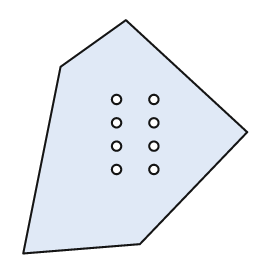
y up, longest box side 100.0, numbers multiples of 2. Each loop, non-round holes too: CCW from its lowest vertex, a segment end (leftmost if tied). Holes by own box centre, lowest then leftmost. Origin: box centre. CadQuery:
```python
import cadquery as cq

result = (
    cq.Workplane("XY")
    .moveTo(-48.0, -50.0)
    .lineTo(2.0, -46.0)
    .lineTo(48.0, 2.0)
    .lineTo(-4.0, 50.0)
    .lineTo(-32.0, 30.0)
    .close()
    .moveTo(-8.0, -14.0)
    .circle(2.0)
    .moveTo(8.0, -14.0)
    .circle(2.0)
    .moveTo(-8.0, -4.0)
    .circle(2.0)
    .moveTo(8.0, -4.0)
    .circle(2.0)
    .moveTo(-8.0, 6.0)
    .circle(2.0)
    .moveTo(8.0, 6.0)
    .circle(2.0)
    .moveTo(-8.0, 16.0)
    .circle(2.0)
    .moveTo(8.0, 16.0)
    .circle(2.0)
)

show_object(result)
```